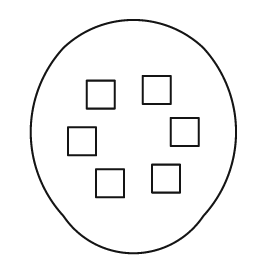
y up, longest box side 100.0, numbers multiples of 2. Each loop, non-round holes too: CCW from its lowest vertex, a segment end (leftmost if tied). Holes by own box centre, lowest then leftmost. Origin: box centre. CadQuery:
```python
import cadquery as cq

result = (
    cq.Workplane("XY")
    .moveTo(-30.0, -34.0)
    .threePointArc((0.0, -50.0), (30.0, -34.0))
    .threePointArc((44.0, 2.0), (30.0, 38.0))
    .threePointArc((0.0, 50.0), (-30.0, 38.0))
    .threePointArc((-44.0, 2.0), (-30.0, -34.0))
    .close()
    .moveTo(-16.0, -26.0)
    .lineTo(-4.0, -26.0)
    .lineTo(-4.0, -14.0)
    .lineTo(-16.0, -14.0)
    .close()
    .moveTo(8.0, -24.0)
    .lineTo(20.0, -24.0)
    .lineTo(20.0, -12.0)
    .lineTo(8.0, -12.0)
    .close()
    .moveTo(-28.0, -8.0)
    .lineTo(-16.0, -8.0)
    .lineTo(-16.0, 4.0)
    .lineTo(-28.0, 4.0)
    .close()
    .moveTo(16.0, -4.0)
    .lineTo(28.0, -4.0)
    .lineTo(28.0, 8.0)
    .lineTo(16.0, 8.0)
    .close()
    .moveTo(-20.0, 12.0)
    .lineTo(-8.0, 12.0)
    .lineTo(-8.0, 24.0)
    .lineTo(-20.0, 24.0)
    .close()
    .moveTo(4.0, 14.0)
    .lineTo(16.0, 14.0)
    .lineTo(16.0, 26.0)
    .lineTo(4.0, 26.0)
    .close()
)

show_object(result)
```